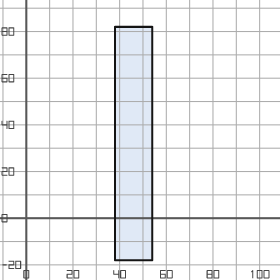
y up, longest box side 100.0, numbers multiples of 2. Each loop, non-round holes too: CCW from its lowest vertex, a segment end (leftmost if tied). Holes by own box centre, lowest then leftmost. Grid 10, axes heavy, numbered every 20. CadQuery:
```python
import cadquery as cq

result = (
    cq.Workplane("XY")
    .moveTo(38.0, -18.0)
    .lineTo(54.0, -18.0)
    .lineTo(54.0, 82.0)
    .lineTo(38.0, 82.0)
    .close()
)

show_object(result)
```